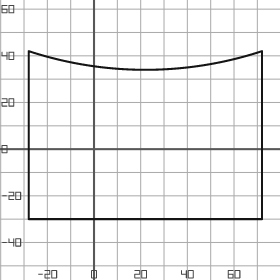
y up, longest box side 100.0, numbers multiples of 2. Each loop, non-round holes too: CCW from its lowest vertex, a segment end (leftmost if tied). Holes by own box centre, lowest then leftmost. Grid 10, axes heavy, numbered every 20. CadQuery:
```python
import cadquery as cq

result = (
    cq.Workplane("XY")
    .moveTo(-28.0, -30.0)
    .lineTo(72.0, -30.0)
    .lineTo(72.0, 42.0)
    .threePointArc((22.0, 34.0), (-28.0, 42.0))
    .close()
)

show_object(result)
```